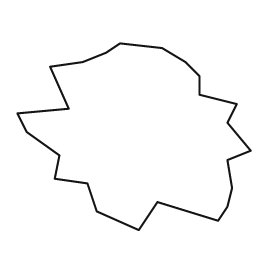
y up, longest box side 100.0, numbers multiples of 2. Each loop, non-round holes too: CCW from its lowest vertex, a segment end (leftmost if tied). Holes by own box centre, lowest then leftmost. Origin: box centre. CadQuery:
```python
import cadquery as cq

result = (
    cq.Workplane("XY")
    .moveTo(2.0, -40.0)
    .lineTo(10.0, -28.0)
    .lineTo(36.0, -36.0)
    .lineTo(40.0, -30.0)
    .lineTo(42.0, -22.0)
    .lineTo(40.0, -10.0)
    .lineTo(50.0, -6.0)
    .lineTo(40.0, 6.0)
    .lineTo(44.0, 14.0)
    .lineTo(28.0, 18.0)
    .lineTo(28.0, 26.0)
    .lineTo(22.0, 32.0)
    .lineTo(12.0, 38.0)
    .lineTo(-6.0, 40.0)
    .lineTo(-12.0, 36.0)
    .lineTo(-22.0, 32.0)
    .lineTo(-36.0, 30.0)
    .lineTo(-28.0, 12.0)
    .lineTo(-50.0, 10.0)
    .lineTo(-46.0, 2.0)
    .lineTo(-32.0, -8.0)
    .lineTo(-34.0, -18.0)
    .lineTo(-20.0, -20.0)
    .lineTo(-16.0, -32.0)
    .close()
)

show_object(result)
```